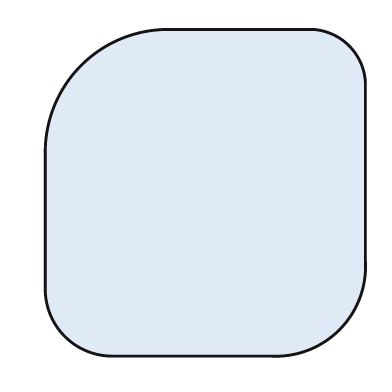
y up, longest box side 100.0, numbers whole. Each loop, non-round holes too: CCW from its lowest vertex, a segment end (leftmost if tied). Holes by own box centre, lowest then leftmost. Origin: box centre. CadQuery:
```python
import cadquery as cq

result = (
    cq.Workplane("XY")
    .moveTo(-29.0, -50.0)
    .lineTo(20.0, -50.0)
    .threePointArc((41.0, -42.0), (49.0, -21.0))
    .lineTo(49.0, 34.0)
    .threePointArc((44.0, 45.0), (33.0, 50.0))
    .lineTo(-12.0, 50.0)
    .threePointArc((-38.0, 39.0), (-49.0, 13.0))
    .lineTo(-49.0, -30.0)
    .threePointArc((-43.0, -44.0), (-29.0, -50.0))
    .close()
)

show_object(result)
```